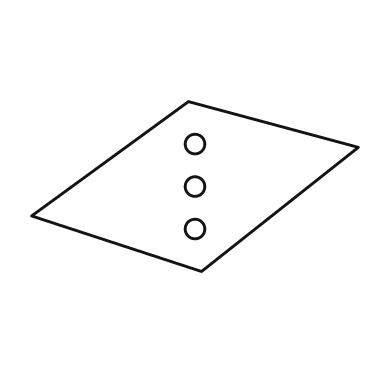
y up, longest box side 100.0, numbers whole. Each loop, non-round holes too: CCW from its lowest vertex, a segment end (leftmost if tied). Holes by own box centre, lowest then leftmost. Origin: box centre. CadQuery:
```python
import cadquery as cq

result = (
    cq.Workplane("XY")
    .moveTo(2.0, -26.0)
    .lineTo(50.0, 12.0)
    .lineTo(-2.0, 26.0)
    .lineTo(-50.0, -9.0)
    .close()
    .moveTo(0.0, -13.0)
    .circle(3.0)
    .moveTo(0.0, 0.0)
    .circle(3.0)
    .moveTo(0.0, 13.0)
    .circle(3.0)
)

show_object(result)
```